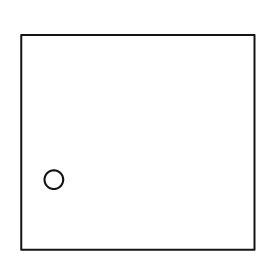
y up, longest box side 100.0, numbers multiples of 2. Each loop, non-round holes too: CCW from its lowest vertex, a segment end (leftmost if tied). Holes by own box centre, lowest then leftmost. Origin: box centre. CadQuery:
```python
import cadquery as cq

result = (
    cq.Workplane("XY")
    .moveTo(-50.0, -46.0)
    .lineTo(50.0, -46.0)
    .lineTo(50.0, 46.0)
    .lineTo(-50.0, 46.0)
    .close()
    .moveTo(-36.0, -16.0)
    .circle(4.0)
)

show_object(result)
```